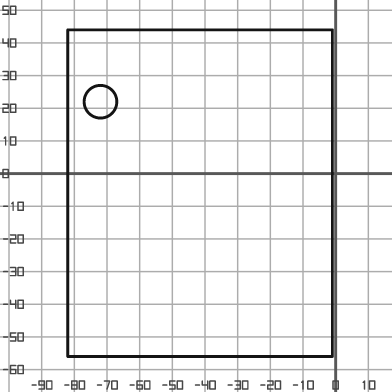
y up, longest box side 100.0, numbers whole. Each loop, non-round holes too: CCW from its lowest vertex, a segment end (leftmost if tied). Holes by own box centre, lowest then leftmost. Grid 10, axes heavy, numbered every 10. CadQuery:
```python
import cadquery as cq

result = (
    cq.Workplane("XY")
    .moveTo(-82.0, -56.0)
    .lineTo(-1.0, -56.0)
    .lineTo(-1.0, 44.0)
    .lineTo(-82.0, 44.0)
    .close()
    .moveTo(-72.0, 22.0)
    .circle(5.0)
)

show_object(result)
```